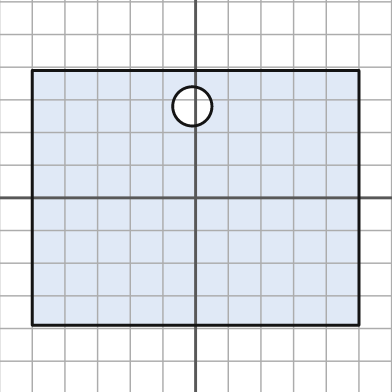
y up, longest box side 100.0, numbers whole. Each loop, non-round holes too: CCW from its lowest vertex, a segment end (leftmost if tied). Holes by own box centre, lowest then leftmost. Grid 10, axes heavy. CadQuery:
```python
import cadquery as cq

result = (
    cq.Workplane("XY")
    .moveTo(-50.0, -39.0)
    .lineTo(50.0, -39.0)
    .lineTo(50.0, 39.0)
    .lineTo(-50.0, 39.0)
    .close()
    .moveTo(-1.0, 28.0)
    .circle(6.0)
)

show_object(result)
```